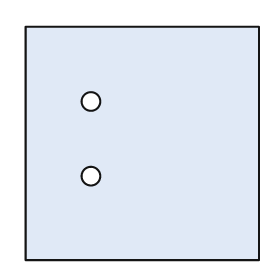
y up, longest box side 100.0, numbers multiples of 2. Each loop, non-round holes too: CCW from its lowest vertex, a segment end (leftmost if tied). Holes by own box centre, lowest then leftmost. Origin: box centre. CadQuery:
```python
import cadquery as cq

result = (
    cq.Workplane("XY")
    .moveTo(-50.0, -50.0)
    .lineTo(50.0, -50.0)
    .lineTo(50.0, 50.0)
    .lineTo(-50.0, 50.0)
    .close()
    .moveTo(-22.0, -14.0)
    .circle(4.0)
    .moveTo(-22.0, 18.0)
    .circle(4.0)
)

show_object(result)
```